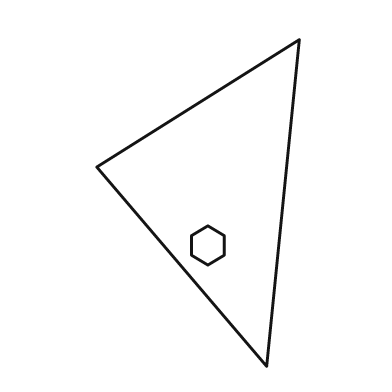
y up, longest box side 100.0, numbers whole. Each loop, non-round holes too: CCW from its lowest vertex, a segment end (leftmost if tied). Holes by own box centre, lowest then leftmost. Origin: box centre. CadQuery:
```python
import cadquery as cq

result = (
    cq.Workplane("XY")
    .moveTo(21.0, -50.0)
    .lineTo(31.0, 50.0)
    .lineTo(-31.0, 11.0)
    .close()
    .moveTo(3.0, -19.0)
    .lineTo(8.0, -16.0)
    .lineTo(8.0, -10.0)
    .lineTo(3.0, -7.0)
    .lineTo(-2.0, -10.0)
    .lineTo(-2.0, -16.0)
    .close()
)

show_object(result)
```